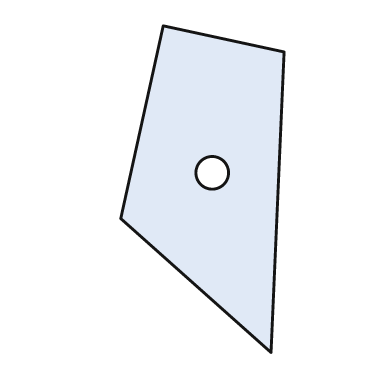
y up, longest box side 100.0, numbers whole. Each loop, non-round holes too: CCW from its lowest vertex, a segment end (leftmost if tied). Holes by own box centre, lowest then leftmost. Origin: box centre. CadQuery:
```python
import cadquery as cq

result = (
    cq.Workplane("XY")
    .moveTo(21.0, -50.0)
    .lineTo(25.0, 42.0)
    .lineTo(-12.0, 50.0)
    .lineTo(-25.0, -9.0)
    .close()
    .moveTo(3.0, 5.0)
    .circle(5.0)
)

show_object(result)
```